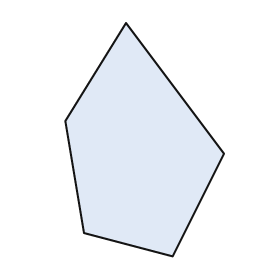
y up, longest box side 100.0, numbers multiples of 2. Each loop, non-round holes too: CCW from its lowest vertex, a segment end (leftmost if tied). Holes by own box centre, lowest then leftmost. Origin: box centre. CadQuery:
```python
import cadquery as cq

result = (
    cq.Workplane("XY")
    .moveTo(12.0, -50.0)
    .lineTo(34.0, -6.0)
    .lineTo(-8.0, 50.0)
    .lineTo(-34.0, 8.0)
    .lineTo(-26.0, -40.0)
    .close()
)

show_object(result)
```